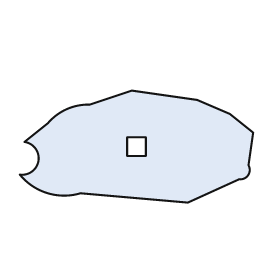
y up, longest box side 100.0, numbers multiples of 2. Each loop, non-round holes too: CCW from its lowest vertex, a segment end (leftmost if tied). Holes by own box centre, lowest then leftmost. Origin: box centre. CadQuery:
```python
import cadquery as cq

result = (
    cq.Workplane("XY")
    .moveTo(22.0, -24.0)
    .lineTo(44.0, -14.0)
    .threePointArc((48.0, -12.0), (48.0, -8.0))
    .lineTo(50.0, 6.0)
    .lineTo(40.0, 14.0)
    .lineTo(26.0, 20.0)
    .lineTo(-2.0, 24.0)
    .lineTo(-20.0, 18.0)
    .threePointArc((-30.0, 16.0), (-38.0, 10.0))
    .lineTo(-48.0, 2.0)
    .threePointArc((-42.0, -6.0), (-50.0, -12.0))
    .threePointArc((-38.0, -20.0), (-24.0, -20.0))
    .close()
    .moveTo(-4.0, -4.0)
    .lineTo(4.0, -4.0)
    .lineTo(4.0, 4.0)
    .lineTo(-4.0, 4.0)
    .close()
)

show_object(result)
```